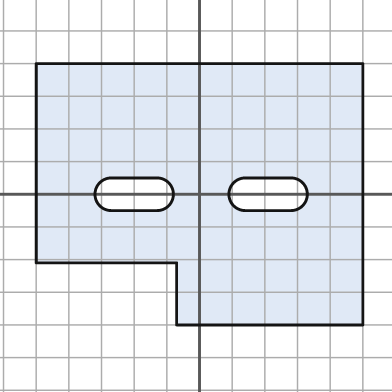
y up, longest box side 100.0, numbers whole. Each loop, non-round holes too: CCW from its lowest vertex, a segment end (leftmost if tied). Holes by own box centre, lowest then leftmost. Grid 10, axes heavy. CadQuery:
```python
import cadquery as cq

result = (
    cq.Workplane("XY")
    .moveTo(-7.0, -40.0)
    .lineTo(50.0, -40.0)
    .lineTo(50.0, 40.0)
    .lineTo(-50.0, 40.0)
    .lineTo(-50.0, -21.0)
    .lineTo(-7.0, -21.0)
    .close()
    .moveTo(-27.0, -5.0)
    .lineTo(-13.0, -5.0)
    .threePointArc((-8.0, 0.0), (-13.0, 5.0))
    .lineTo(-27.0, 5.0)
    .threePointArc((-32.0, 0.0), (-27.0, -5.0))
    .close()
    .moveTo(14.0, -5.0)
    .lineTo(28.0, -5.0)
    .threePointArc((33.0, 0.0), (28.0, 5.0))
    .lineTo(14.0, 5.0)
    .threePointArc((9.0, 0.0), (14.0, -5.0))
    .close()
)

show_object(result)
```